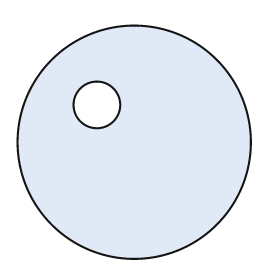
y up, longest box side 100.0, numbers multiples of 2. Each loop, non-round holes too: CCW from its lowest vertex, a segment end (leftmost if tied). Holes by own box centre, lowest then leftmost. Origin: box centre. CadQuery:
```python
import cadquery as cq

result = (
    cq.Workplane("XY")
    .moveTo(0.0, 0.0)
    .circle(50.0)
    .moveTo(-16.0, 16.0)
    .circle(10.0)
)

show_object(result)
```